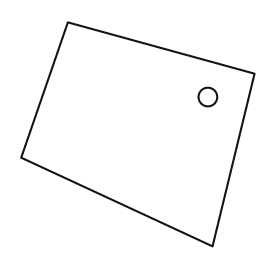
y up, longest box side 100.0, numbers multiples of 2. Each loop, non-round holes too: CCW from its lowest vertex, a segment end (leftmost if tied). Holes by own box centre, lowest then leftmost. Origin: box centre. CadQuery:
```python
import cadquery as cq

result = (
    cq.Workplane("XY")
    .moveTo(32.0, -48.0)
    .lineTo(50.0, 26.0)
    .lineTo(-30.0, 48.0)
    .lineTo(-50.0, -10.0)
    .close()
    .moveTo(30.0, 16.0)
    .circle(4.0)
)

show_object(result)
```